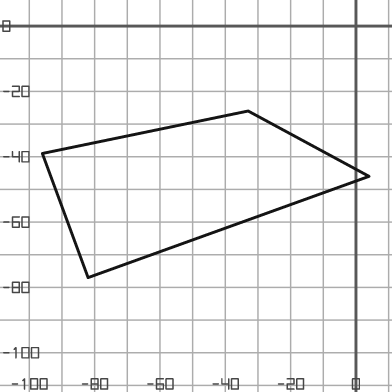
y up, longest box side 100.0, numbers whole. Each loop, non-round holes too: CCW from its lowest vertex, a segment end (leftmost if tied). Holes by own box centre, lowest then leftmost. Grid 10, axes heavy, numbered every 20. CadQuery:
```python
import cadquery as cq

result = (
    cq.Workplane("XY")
    .moveTo(-82.0, -77.0)
    .lineTo(4.0, -46.0)
    .lineTo(-33.0, -26.0)
    .lineTo(-96.0, -39.0)
    .close()
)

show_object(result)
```